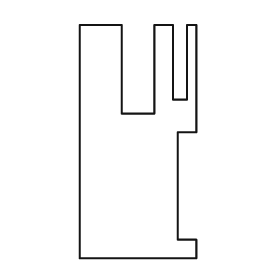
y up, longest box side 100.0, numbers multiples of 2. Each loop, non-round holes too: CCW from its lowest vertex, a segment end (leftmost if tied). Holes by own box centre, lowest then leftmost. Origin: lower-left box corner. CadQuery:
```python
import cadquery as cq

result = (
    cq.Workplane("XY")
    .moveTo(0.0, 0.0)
    .lineTo(50.0, 0.0)
    .lineTo(50.0, 8.0)
    .lineTo(42.0, 8.0)
    .lineTo(42.0, 54.0)
    .lineTo(50.0, 54.0)
    .lineTo(50.0, 100.0)
    .lineTo(46.0, 100.0)
    .lineTo(46.0, 68.0)
    .lineTo(40.0, 68.0)
    .lineTo(40.0, 100.0)
    .lineTo(32.0, 100.0)
    .lineTo(32.0, 62.0)
    .lineTo(18.0, 62.0)
    .lineTo(18.0, 100.0)
    .lineTo(0.0, 100.0)
    .close()
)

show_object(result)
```